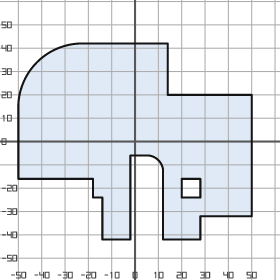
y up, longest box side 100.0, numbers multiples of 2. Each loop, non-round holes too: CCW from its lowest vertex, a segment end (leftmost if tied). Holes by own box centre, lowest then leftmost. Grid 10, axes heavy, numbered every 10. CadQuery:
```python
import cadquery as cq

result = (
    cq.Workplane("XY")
    .moveTo(-14.0, -42.0)
    .lineTo(-2.0, -42.0)
    .lineTo(-2.0, -6.0)
    .lineTo(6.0, -6.0)
    .threePointArc((10.0, -8.0), (12.0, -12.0))
    .lineTo(12.0, -42.0)
    .lineTo(28.0, -42.0)
    .lineTo(28.0, -32.0)
    .lineTo(50.0, -32.0)
    .lineTo(50.0, 20.0)
    .lineTo(14.0, 20.0)
    .lineTo(14.0, 42.0)
    .lineTo(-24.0, 42.0)
    .threePointArc((-42.0, 34.0), (-50.0, 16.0))
    .lineTo(-50.0, -16.0)
    .lineTo(-18.0, -16.0)
    .lineTo(-18.0, -24.0)
    .lineTo(-14.0, -24.0)
    .close()
    .moveTo(20.0, -24.0)
    .lineTo(28.0, -24.0)
    .lineTo(28.0, -16.0)
    .lineTo(20.0, -16.0)
    .close()
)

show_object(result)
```